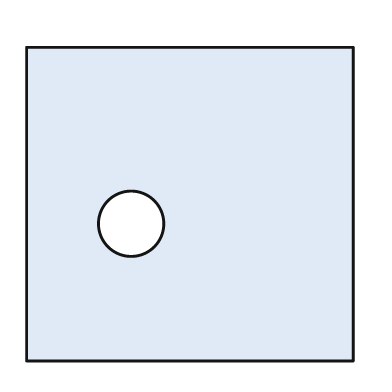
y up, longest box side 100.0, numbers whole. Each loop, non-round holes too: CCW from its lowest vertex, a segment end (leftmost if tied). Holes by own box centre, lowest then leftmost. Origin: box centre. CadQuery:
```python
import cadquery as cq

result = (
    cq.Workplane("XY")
    .moveTo(-50.0, -48.0)
    .lineTo(50.0, -48.0)
    .lineTo(50.0, 48.0)
    .lineTo(-50.0, 48.0)
    .close()
    .moveTo(-18.0, -6.0)
    .circle(10.0)
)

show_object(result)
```